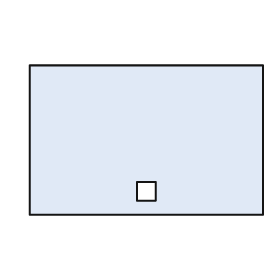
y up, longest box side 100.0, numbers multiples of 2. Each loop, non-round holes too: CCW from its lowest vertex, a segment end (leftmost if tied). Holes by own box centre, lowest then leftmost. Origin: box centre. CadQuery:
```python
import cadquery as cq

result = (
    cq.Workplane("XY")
    .moveTo(-50.0, -32.0)
    .lineTo(50.0, -32.0)
    .lineTo(50.0, 32.0)
    .lineTo(-50.0, 32.0)
    .close()
    .moveTo(-4.0, -26.0)
    .lineTo(4.0, -26.0)
    .lineTo(4.0, -18.0)
    .lineTo(-4.0, -18.0)
    .close()
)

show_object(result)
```